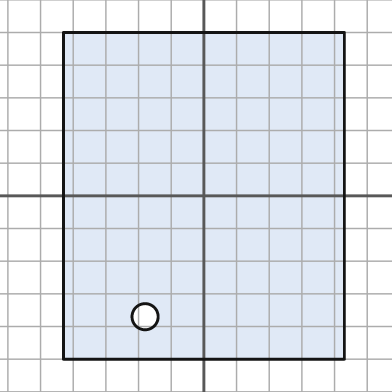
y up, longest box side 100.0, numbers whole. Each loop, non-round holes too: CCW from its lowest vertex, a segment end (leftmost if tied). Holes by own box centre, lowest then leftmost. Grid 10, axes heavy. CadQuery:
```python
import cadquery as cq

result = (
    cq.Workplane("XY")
    .moveTo(-43.0, -50.0)
    .lineTo(43.0, -50.0)
    .lineTo(43.0, 50.0)
    .lineTo(-43.0, 50.0)
    .close()
    .moveTo(-18.0, -37.0)
    .circle(4.0)
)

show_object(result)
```